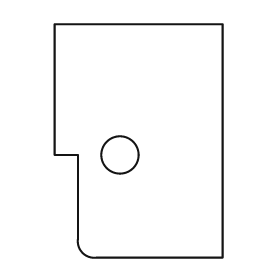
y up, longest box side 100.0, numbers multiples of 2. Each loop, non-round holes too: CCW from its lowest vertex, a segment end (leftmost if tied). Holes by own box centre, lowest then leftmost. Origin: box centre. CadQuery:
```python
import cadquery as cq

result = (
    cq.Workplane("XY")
    .moveTo(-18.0, -50.0)
    .lineTo(36.0, -50.0)
    .lineTo(36.0, 50.0)
    .lineTo(-36.0, 50.0)
    .lineTo(-36.0, -6.0)
    .lineTo(-26.0, -6.0)
    .lineTo(-26.0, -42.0)
    .threePointArc((-24.0, -48.0), (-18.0, -50.0))
    .close()
    .moveTo(-8.0, -6.0)
    .circle(8.0)
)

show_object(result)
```